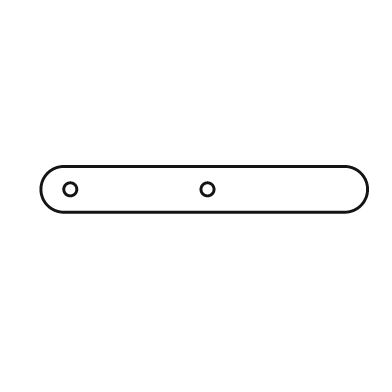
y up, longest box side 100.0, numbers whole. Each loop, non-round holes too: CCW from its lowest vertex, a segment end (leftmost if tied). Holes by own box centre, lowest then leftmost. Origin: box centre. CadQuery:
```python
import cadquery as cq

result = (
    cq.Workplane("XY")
    .moveTo(-43.0, -7.0)
    .lineTo(43.0, -7.0)
    .threePointArc((50.0, 0.0), (43.0, 7.0))
    .lineTo(-43.0, 7.0)
    .threePointArc((-50.0, 0.0), (-43.0, -7.0))
    .close()
    .moveTo(-41.0, 0.0)
    .circle(2.0)
    .moveTo(1.0, 0.0)
    .circle(2.0)
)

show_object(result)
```